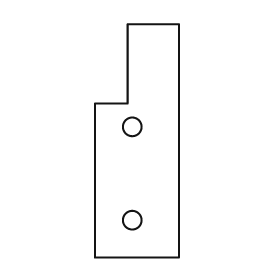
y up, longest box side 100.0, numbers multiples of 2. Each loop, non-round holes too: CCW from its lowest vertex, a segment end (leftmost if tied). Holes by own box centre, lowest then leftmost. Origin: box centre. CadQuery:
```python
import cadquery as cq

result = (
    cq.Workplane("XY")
    .moveTo(-18.0, -50.0)
    .lineTo(18.0, -50.0)
    .lineTo(18.0, 50.0)
    .lineTo(-4.0, 50.0)
    .lineTo(-4.0, 16.0)
    .lineTo(-18.0, 16.0)
    .close()
    .moveTo(-2.0, -34.0)
    .circle(4.0)
    .moveTo(-2.0, 6.0)
    .circle(4.0)
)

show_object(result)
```